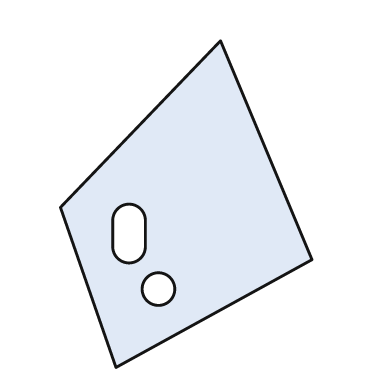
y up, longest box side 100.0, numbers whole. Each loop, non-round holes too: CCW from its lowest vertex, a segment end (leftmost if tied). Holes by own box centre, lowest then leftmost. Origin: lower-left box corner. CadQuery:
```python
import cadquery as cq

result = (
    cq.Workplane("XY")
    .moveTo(17.0, 0.0)
    .lineTo(77.0, 33.0)
    .lineTo(49.0, 100.0)
    .lineTo(0.0, 49.0)
    .close()
    .moveTo(30.0, 24.0)
    .circle(5.0)
    .moveTo(16.0, 37.0)
    .threePointArc((21.0, 32.0), (26.0, 37.0))
    .lineTo(26.0, 45.0)
    .threePointArc((21.0, 50.0), (16.0, 45.0))
    .close()
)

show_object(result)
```